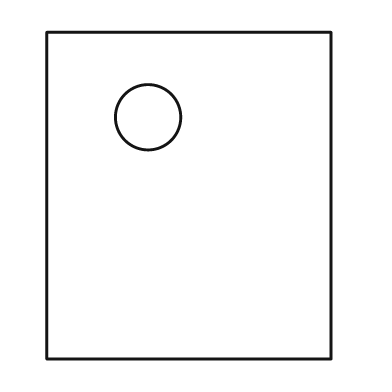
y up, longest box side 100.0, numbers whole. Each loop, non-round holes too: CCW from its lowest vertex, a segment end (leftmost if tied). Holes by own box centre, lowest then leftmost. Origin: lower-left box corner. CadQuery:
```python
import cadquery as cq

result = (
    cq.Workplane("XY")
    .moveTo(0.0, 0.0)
    .lineTo(87.0, 0.0)
    .lineTo(87.0, 100.0)
    .lineTo(0.0, 100.0)
    .close()
    .moveTo(31.0, 74.0)
    .circle(10.0)
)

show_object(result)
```